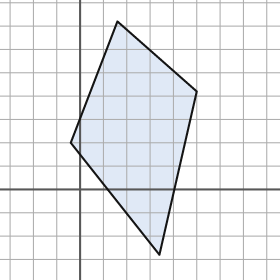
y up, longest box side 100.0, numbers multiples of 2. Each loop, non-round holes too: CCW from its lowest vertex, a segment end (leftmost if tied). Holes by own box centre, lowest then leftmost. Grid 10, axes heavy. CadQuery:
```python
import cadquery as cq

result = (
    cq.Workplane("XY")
    .moveTo(34.0, -28.0)
    .lineTo(50.0, 42.0)
    .lineTo(16.0, 72.0)
    .lineTo(-4.0, 20.0)
    .close()
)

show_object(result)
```